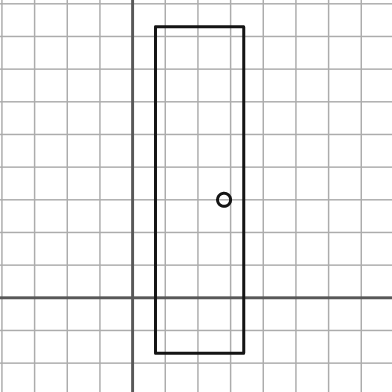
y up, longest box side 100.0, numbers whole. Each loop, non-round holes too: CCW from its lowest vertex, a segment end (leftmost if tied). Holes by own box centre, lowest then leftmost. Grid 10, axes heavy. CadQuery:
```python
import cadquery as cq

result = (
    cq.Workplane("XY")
    .moveTo(7.0, -17.0)
    .lineTo(34.0, -17.0)
    .lineTo(34.0, 83.0)
    .lineTo(7.0, 83.0)
    .close()
    .moveTo(28.0, 30.0)
    .circle(2.0)
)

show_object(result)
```